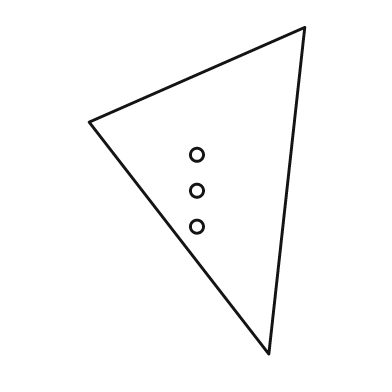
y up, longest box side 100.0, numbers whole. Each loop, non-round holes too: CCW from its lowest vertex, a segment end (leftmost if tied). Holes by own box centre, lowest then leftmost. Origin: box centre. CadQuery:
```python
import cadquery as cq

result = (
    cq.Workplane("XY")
    .moveTo(22.0, -50.0)
    .lineTo(33.0, 50.0)
    .lineTo(-33.0, 21.0)
    .close()
    .moveTo(0.0, -11.0)
    .circle(2.0)
    .moveTo(0.0, 0.0)
    .circle(2.0)
    .moveTo(0.0, 11.0)
    .circle(2.0)
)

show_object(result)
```